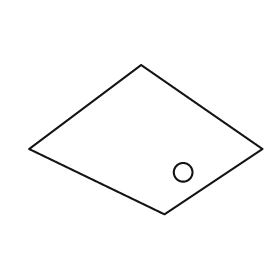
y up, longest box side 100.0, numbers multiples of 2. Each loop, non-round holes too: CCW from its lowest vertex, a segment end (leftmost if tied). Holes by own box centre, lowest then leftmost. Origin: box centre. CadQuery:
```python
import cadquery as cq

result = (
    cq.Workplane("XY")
    .moveTo(8.0, -32.0)
    .lineTo(50.0, -4.0)
    .lineTo(-2.0, 32.0)
    .lineTo(-50.0, -4.0)
    .close()
    .moveTo(16.0, -14.0)
    .circle(4.0)
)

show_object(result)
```